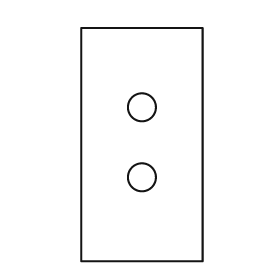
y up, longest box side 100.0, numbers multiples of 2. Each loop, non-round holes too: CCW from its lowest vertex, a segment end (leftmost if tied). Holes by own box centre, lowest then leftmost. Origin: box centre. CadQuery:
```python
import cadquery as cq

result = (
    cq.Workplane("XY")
    .moveTo(-26.0, -50.0)
    .lineTo(26.0, -50.0)
    .lineTo(26.0, 50.0)
    .lineTo(-26.0, 50.0)
    .close()
    .moveTo(0.0, -14.0)
    .circle(6.0)
    .moveTo(0.0, 16.0)
    .circle(6.0)
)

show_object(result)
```